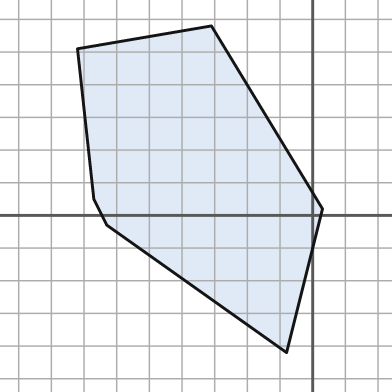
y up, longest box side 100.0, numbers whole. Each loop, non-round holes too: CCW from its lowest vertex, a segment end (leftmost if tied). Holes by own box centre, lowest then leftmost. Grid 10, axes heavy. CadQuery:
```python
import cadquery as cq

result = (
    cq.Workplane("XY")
    .moveTo(-8.0, -42.0)
    .lineTo(3.0, 2.0)
    .lineTo(-31.0, 58.0)
    .lineTo(-72.0, 51.0)
    .lineTo(-67.0, 5.0)
    .lineTo(-63.0, -3.0)
    .close()
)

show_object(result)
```